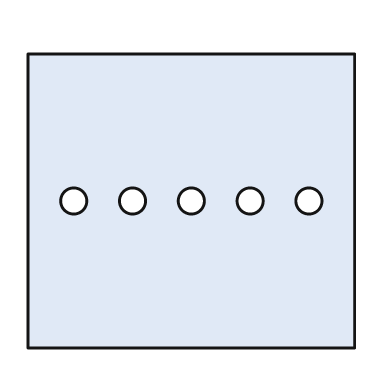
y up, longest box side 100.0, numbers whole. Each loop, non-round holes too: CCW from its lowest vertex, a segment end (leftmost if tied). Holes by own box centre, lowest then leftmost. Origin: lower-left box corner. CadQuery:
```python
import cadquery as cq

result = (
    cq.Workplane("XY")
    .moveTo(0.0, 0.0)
    .lineTo(100.0, 0.0)
    .lineTo(100.0, 90.0)
    .lineTo(0.0, 90.0)
    .close()
    .moveTo(14.0, 45.0)
    .circle(4.0)
    .moveTo(32.0, 45.0)
    .circle(4.0)
    .moveTo(50.0, 45.0)
    .circle(4.0)
    .moveTo(68.0, 45.0)
    .circle(4.0)
    .moveTo(86.0, 45.0)
    .circle(4.0)
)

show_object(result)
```